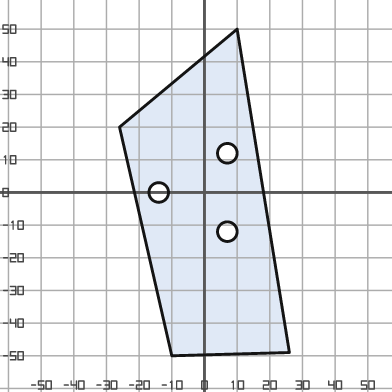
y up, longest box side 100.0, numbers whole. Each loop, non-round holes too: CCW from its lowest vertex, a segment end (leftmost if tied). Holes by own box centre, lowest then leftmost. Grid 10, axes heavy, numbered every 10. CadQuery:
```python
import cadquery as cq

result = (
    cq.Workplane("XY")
    .moveTo(-10.0, -50.0)
    .lineTo(26.0, -49.0)
    .lineTo(10.0, 50.0)
    .lineTo(-26.0, 20.0)
    .close()
    .moveTo(7.0, -12.0)
    .circle(3.0)
    .moveTo(-14.0, 0.0)
    .circle(3.0)
    .moveTo(7.0, 12.0)
    .circle(3.0)
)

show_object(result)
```